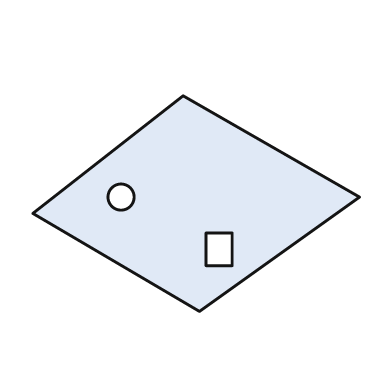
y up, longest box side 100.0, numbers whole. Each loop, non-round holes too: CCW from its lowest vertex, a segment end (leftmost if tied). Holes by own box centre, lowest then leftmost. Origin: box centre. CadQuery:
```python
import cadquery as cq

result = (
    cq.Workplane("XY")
    .moveTo(1.0, -33.0)
    .lineTo(50.0, 2.0)
    .lineTo(-4.0, 33.0)
    .lineTo(-50.0, -3.0)
    .close()
    .moveTo(3.0, -19.0)
    .lineTo(11.0, -19.0)
    .lineTo(11.0, -9.0)
    .lineTo(3.0, -9.0)
    .close()
    .moveTo(-23.0, 2.0)
    .circle(4.0)
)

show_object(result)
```